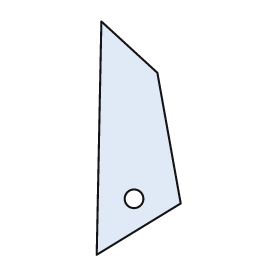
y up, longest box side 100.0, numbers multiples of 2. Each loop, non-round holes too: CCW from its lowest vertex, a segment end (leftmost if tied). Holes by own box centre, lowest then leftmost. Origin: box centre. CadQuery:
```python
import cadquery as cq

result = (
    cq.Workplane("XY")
    .moveTo(-18.0, -50.0)
    .lineTo(18.0, -28.0)
    .lineTo(8.0, 28.0)
    .lineTo(-16.0, 50.0)
    .close()
    .moveTo(-2.0, -26.0)
    .circle(4.0)
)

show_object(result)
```